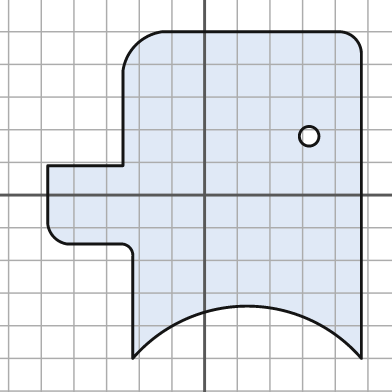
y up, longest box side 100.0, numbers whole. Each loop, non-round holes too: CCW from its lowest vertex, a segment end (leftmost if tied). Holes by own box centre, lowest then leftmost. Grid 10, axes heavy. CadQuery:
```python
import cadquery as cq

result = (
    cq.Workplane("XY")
    .moveTo(-22.0, -50.0)
    .threePointArc((13.0, -34.0), (48.0, -50.0))
    .lineTo(48.0, 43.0)
    .threePointArc((46.0, 48.0), (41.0, 50.0))
    .lineTo(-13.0, 50.0)
    .threePointArc((-21.0, 46.0), (-25.0, 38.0))
    .lineTo(-25.0, 9.0)
    .lineTo(-48.0, 9.0)
    .lineTo(-48.0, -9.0)
    .threePointArc((-46.0, -13.0), (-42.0, -15.0))
    .lineTo(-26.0, -15.0)
    .threePointArc((-23.0, -16.0), (-22.0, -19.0))
    .close()
    .moveTo(32.0, 18.0)
    .circle(3.0)
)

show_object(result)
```